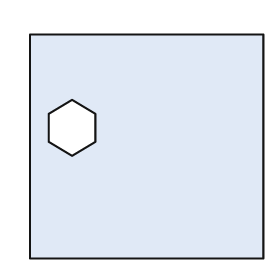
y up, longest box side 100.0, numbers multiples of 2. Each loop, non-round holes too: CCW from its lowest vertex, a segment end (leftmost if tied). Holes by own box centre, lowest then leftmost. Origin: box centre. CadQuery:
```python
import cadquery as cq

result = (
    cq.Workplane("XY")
    .moveTo(-50.0, -48.0)
    .lineTo(50.0, -48.0)
    .lineTo(50.0, 48.0)
    .lineTo(-50.0, 48.0)
    .close()
    .moveTo(-32.0, -4.0)
    .lineTo(-22.0, 2.0)
    .lineTo(-22.0, 14.0)
    .lineTo(-32.0, 20.0)
    .lineTo(-42.0, 14.0)
    .lineTo(-42.0, 2.0)
    .close()
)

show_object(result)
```